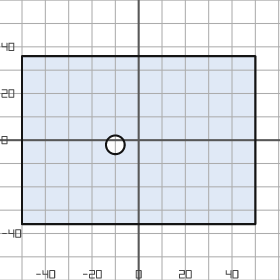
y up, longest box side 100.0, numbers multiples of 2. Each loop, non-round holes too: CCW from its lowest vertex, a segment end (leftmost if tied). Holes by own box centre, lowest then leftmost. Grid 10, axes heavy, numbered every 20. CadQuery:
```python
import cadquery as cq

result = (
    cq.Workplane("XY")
    .moveTo(-50.0, -36.0)
    .lineTo(50.0, -36.0)
    .lineTo(50.0, 36.0)
    .lineTo(-50.0, 36.0)
    .close()
    .moveTo(-10.0, -2.0)
    .circle(4.0)
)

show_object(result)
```